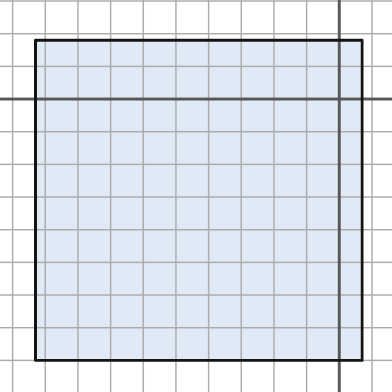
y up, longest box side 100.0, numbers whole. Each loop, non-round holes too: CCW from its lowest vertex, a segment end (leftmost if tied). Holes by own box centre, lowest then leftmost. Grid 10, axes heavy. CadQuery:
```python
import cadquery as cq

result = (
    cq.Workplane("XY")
    .moveTo(-93.0, -80.0)
    .lineTo(7.0, -80.0)
    .lineTo(7.0, 18.0)
    .lineTo(-93.0, 18.0)
    .close()
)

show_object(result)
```